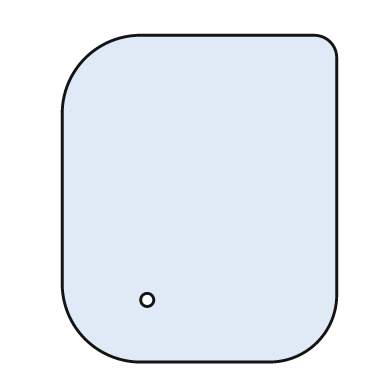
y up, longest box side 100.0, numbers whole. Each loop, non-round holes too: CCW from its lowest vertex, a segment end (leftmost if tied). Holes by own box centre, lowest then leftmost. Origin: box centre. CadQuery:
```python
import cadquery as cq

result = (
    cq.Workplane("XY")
    .moveTo(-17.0, -50.0)
    .lineTo(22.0, -50.0)
    .threePointArc((36.0, -44.0), (42.0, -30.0))
    .lineTo(42.0, 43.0)
    .threePointArc((40.0, 48.0), (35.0, 50.0))
    .lineTo(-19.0, 50.0)
    .threePointArc((-35.0, 43.0), (-42.0, 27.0))
    .lineTo(-42.0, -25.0)
    .threePointArc((-35.0, -43.0), (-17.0, -50.0))
    .close()
    .moveTo(-16.0, -31.0)
    .circle(2.0)
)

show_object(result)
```